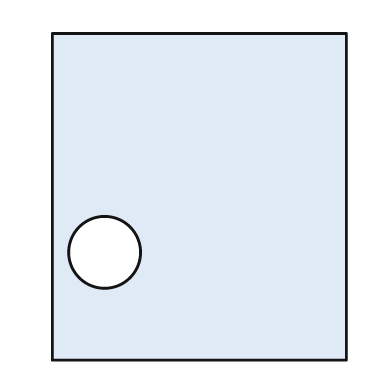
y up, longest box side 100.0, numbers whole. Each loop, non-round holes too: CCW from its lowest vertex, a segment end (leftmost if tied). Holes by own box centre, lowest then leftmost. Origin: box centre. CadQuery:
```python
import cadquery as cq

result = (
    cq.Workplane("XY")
    .moveTo(-45.0, -50.0)
    .lineTo(45.0, -50.0)
    .lineTo(45.0, 50.0)
    .lineTo(-45.0, 50.0)
    .close()
    .moveTo(-29.0, -17.0)
    .circle(11.0)
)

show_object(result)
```